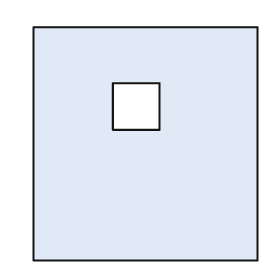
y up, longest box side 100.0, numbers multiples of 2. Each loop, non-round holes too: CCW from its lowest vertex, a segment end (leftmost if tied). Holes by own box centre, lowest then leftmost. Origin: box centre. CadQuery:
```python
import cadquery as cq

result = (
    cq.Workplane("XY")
    .moveTo(-48.0, -50.0)
    .lineTo(48.0, -50.0)
    .lineTo(48.0, 50.0)
    .lineTo(-48.0, 50.0)
    .close()
    .moveTo(-14.0, 6.0)
    .lineTo(6.0, 6.0)
    .lineTo(6.0, 26.0)
    .lineTo(-14.0, 26.0)
    .close()
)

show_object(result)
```